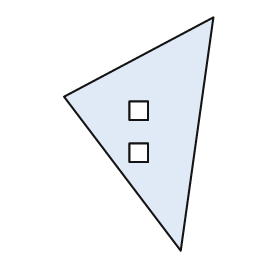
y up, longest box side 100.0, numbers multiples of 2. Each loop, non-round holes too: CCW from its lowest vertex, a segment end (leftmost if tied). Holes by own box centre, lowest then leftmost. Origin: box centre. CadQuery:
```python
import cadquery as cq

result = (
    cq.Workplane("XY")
    .moveTo(18.0, -50.0)
    .lineTo(32.0, 50.0)
    .lineTo(-32.0, 16.0)
    .close()
    .moveTo(-4.0, -12.0)
    .lineTo(4.0, -12.0)
    .lineTo(4.0, -4.0)
    .lineTo(-4.0, -4.0)
    .close()
    .moveTo(-4.0, 6.0)
    .lineTo(4.0, 6.0)
    .lineTo(4.0, 14.0)
    .lineTo(-4.0, 14.0)
    .close()
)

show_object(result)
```